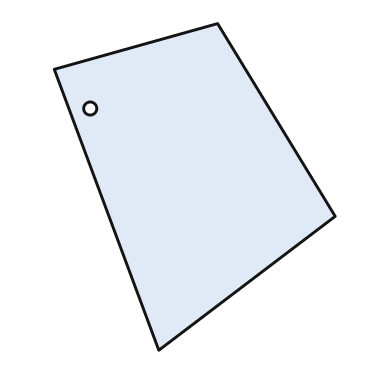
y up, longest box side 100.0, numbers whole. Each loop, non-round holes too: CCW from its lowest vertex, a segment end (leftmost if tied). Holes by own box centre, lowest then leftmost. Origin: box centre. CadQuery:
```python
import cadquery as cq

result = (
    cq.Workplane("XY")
    .moveTo(-11.0, -50.0)
    .lineTo(43.0, -9.0)
    .lineTo(7.0, 50.0)
    .lineTo(-43.0, 36.0)
    .close()
    .moveTo(-32.0, 24.0)
    .circle(2.0)
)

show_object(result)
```